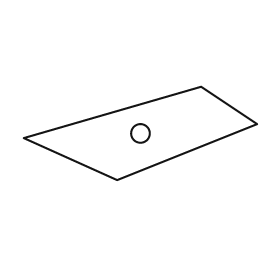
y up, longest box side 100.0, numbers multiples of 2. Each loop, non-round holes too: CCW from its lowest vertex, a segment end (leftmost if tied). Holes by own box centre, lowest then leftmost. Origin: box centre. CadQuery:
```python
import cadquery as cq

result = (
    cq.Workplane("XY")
    .moveTo(-10.0, -20.0)
    .lineTo(50.0, 4.0)
    .lineTo(26.0, 20.0)
    .lineTo(-50.0, -2.0)
    .close()
    .moveTo(0.0, 0.0)
    .circle(4.0)
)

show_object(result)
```